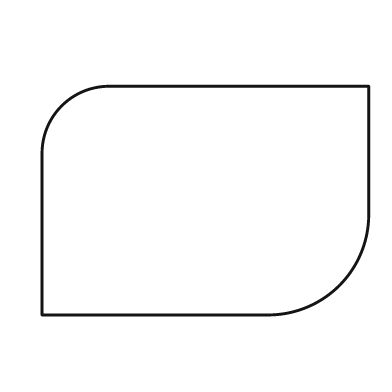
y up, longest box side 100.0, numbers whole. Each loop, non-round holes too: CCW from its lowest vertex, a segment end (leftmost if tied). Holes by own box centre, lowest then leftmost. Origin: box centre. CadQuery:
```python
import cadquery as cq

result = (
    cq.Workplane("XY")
    .moveTo(-50.0, -35.0)
    .lineTo(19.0, -35.0)
    .threePointArc((41.0, -26.0), (50.0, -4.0))
    .lineTo(50.0, 35.0)
    .lineTo(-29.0, 35.0)
    .threePointArc((-44.0, 29.0), (-50.0, 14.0))
    .close()
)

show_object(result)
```